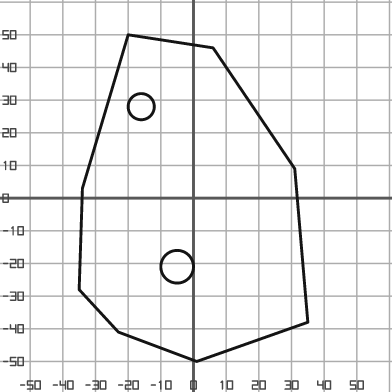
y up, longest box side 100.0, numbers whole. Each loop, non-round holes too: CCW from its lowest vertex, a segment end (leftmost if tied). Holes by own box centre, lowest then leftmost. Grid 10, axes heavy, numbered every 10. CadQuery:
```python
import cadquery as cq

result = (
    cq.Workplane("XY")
    .moveTo(1.0, -50.0)
    .lineTo(35.0, -38.0)
    .lineTo(31.0, 9.0)
    .lineTo(6.0, 46.0)
    .lineTo(-20.0, 50.0)
    .lineTo(-34.0, 3.0)
    .lineTo(-35.0, -28.0)
    .lineTo(-23.0, -41.0)
    .close()
    .moveTo(-5.0, -21.0)
    .circle(5.0)
    .moveTo(-16.0, 28.0)
    .circle(4.0)
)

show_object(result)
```